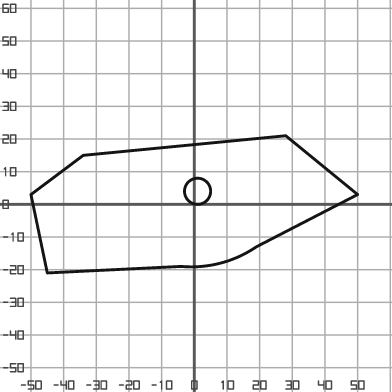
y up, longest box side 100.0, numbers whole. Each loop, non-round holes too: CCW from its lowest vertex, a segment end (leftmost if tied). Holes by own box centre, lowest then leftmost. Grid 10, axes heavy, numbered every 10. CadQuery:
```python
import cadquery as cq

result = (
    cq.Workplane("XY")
    .moveTo(-45.0, -21.0)
    .lineTo(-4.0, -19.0)
    .threePointArc((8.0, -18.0), (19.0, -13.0))
    .lineTo(50.0, 3.0)
    .lineTo(28.0, 21.0)
    .lineTo(-34.0, 15.0)
    .lineTo(-50.0, 3.0)
    .close()
    .moveTo(1.0, 4.0)
    .circle(4.0)
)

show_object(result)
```